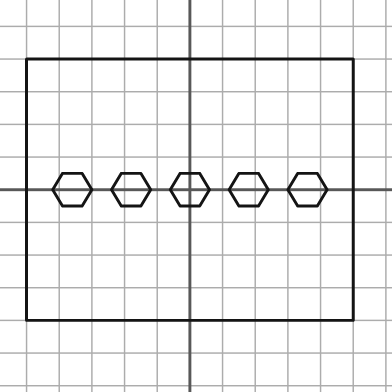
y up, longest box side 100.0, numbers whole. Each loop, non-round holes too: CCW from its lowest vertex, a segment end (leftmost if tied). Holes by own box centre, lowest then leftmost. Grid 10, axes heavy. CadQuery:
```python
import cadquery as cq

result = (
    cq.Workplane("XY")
    .moveTo(-50.0, -40.0)
    .lineTo(50.0, -40.0)
    .lineTo(50.0, 40.0)
    .lineTo(-50.0, 40.0)
    .close()
    .moveTo(-39.0, -5.0)
    .lineTo(-33.0, -5.0)
    .lineTo(-30.0, 0.0)
    .lineTo(-33.0, 5.0)
    .lineTo(-39.0, 5.0)
    .lineTo(-42.0, 0.0)
    .close()
    .moveTo(-21.0, -5.0)
    .lineTo(-15.0, -5.0)
    .lineTo(-12.0, 0.0)
    .lineTo(-15.0, 5.0)
    .lineTo(-21.0, 5.0)
    .lineTo(-24.0, 0.0)
    .close()
    .moveTo(-3.0, -5.0)
    .lineTo(3.0, -5.0)
    .lineTo(6.0, 0.0)
    .lineTo(3.0, 5.0)
    .lineTo(-3.0, 5.0)
    .lineTo(-6.0, 0.0)
    .close()
    .moveTo(15.0, -5.0)
    .lineTo(21.0, -5.0)
    .lineTo(24.0, 0.0)
    .lineTo(21.0, 5.0)
    .lineTo(15.0, 5.0)
    .lineTo(12.0, 0.0)
    .close()
    .moveTo(33.0, -5.0)
    .lineTo(39.0, -5.0)
    .lineTo(42.0, 0.0)
    .lineTo(39.0, 5.0)
    .lineTo(33.0, 5.0)
    .lineTo(30.0, 0.0)
    .close()
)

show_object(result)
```